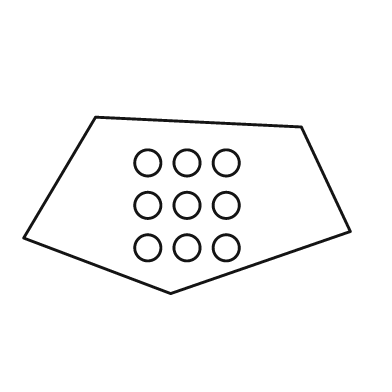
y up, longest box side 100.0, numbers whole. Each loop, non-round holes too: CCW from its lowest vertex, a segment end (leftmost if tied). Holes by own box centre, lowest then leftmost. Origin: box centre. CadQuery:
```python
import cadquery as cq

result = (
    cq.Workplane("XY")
    .moveTo(-5.0, -27.0)
    .lineTo(50.0, -8.0)
    .lineTo(35.0, 24.0)
    .lineTo(-28.0, 27.0)
    .lineTo(-50.0, -10.0)
    .close()
    .moveTo(-12.0, -13.0)
    .circle(4.0)
    .moveTo(0.0, -13.0)
    .circle(4.0)
    .moveTo(12.0, -13.0)
    .circle(4.0)
    .moveTo(-12.0, 0.0)
    .circle(4.0)
    .moveTo(0.0, 0.0)
    .circle(4.0)
    .moveTo(12.0, 0.0)
    .circle(4.0)
    .moveTo(-12.0, 13.0)
    .circle(4.0)
    .moveTo(0.0, 13.0)
    .circle(4.0)
    .moveTo(12.0, 13.0)
    .circle(4.0)
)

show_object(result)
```